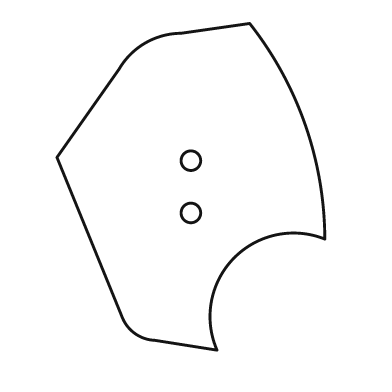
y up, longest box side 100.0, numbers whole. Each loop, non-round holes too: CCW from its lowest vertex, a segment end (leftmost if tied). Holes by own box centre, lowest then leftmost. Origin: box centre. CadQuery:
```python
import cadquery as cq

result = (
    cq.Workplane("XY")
    .moveTo(8.0, -50.0)
    .threePointArc((13.0, -22.0), (41.0, -16.0))
    .threePointArc((35.0, 19.0), (18.0, 50.0))
    .lineTo(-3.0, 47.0)
    .threePointArc((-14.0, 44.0), (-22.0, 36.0))
    .lineTo(-41.0, 9.0)
    .lineTo(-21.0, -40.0)
    .threePointArc((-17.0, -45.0), (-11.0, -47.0))
    .close()
    .moveTo(0.0, -8.0)
    .circle(3.0)
    .moveTo(0.0, 8.0)
    .circle(3.0)
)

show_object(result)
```